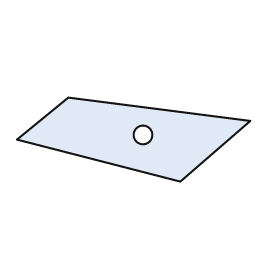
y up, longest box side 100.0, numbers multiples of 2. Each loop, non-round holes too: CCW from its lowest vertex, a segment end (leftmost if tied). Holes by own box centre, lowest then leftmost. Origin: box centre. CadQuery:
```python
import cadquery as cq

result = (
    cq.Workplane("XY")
    .moveTo(20.0, -18.0)
    .lineTo(50.0, 8.0)
    .lineTo(-28.0, 18.0)
    .lineTo(-50.0, 0.0)
    .close()
    .moveTo(4.0, 2.0)
    .circle(4.0)
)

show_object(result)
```